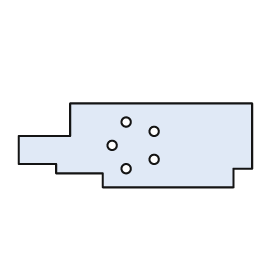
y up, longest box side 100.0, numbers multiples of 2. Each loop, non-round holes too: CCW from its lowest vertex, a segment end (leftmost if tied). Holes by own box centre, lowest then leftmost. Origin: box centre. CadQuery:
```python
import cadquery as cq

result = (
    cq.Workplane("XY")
    .moveTo(-14.0, -18.0)
    .lineTo(42.0, -18.0)
    .lineTo(42.0, -10.0)
    .lineTo(50.0, -10.0)
    .lineTo(50.0, 18.0)
    .lineTo(-28.0, 18.0)
    .lineTo(-28.0, 4.0)
    .lineTo(-50.0, 4.0)
    .lineTo(-50.0, -8.0)
    .lineTo(-34.0, -8.0)
    .lineTo(-34.0, -12.0)
    .lineTo(-14.0, -12.0)
    .close()
    .moveTo(-4.0, -10.0)
    .circle(2.0)
    .moveTo(8.0, -6.0)
    .circle(2.0)
    .moveTo(-10.0, 0.0)
    .circle(2.0)
    .moveTo(8.0, 6.0)
    .circle(2.0)
    .moveTo(-4.0, 10.0)
    .circle(2.0)
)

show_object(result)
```